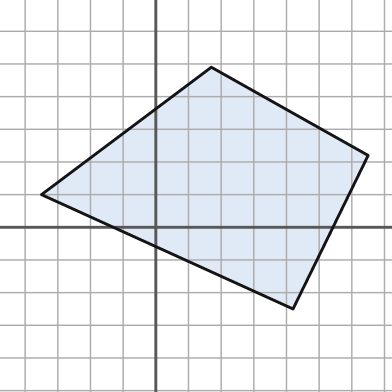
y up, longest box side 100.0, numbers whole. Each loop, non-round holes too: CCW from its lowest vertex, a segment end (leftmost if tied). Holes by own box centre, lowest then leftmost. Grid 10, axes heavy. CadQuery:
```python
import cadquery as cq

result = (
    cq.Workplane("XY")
    .moveTo(42.0, -25.0)
    .lineTo(65.0, 22.0)
    .lineTo(17.0, 49.0)
    .lineTo(-35.0, 10.0)
    .close()
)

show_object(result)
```